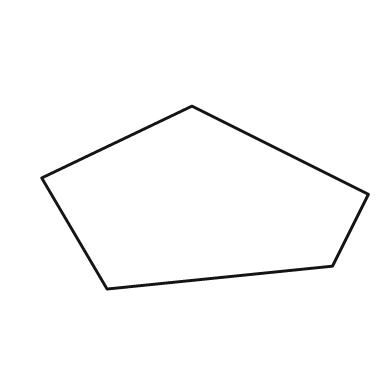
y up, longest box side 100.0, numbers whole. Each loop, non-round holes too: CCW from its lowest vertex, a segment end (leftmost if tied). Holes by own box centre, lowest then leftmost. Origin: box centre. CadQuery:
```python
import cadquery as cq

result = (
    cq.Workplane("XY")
    .moveTo(-30.0, -28.0)
    .lineTo(39.0, -21.0)
    .lineTo(50.0, 1.0)
    .lineTo(-4.0, 28.0)
    .lineTo(-50.0, 6.0)
    .close()
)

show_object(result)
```